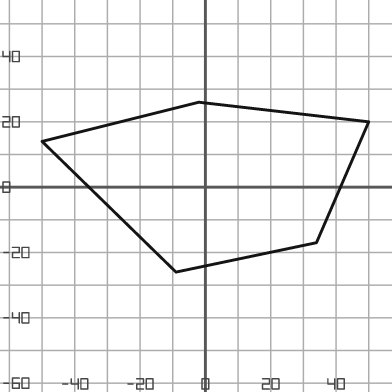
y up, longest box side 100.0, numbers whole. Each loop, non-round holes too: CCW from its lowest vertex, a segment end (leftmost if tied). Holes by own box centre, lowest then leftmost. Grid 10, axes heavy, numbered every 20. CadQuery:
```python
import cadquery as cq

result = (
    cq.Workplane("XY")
    .moveTo(-9.0, -26.0)
    .lineTo(34.0, -17.0)
    .lineTo(50.0, 20.0)
    .lineTo(-2.0, 26.0)
    .lineTo(-50.0, 14.0)
    .close()
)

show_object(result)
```